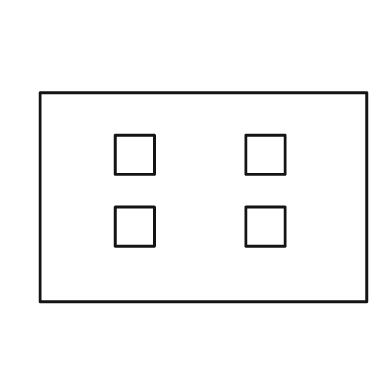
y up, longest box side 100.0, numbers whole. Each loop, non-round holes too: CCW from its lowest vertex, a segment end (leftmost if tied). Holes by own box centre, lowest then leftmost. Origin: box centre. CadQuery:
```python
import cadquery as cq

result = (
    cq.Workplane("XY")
    .moveTo(-50.0, -32.0)
    .lineTo(50.0, -32.0)
    .lineTo(50.0, 32.0)
    .lineTo(-50.0, 32.0)
    .close()
    .moveTo(-27.0, -15.0)
    .lineTo(-15.0, -15.0)
    .lineTo(-15.0, -3.0)
    .lineTo(-27.0, -3.0)
    .close()
    .moveTo(13.0, -15.0)
    .lineTo(25.0, -15.0)
    .lineTo(25.0, -3.0)
    .lineTo(13.0, -3.0)
    .close()
    .moveTo(-27.0, 7.0)
    .lineTo(-15.0, 7.0)
    .lineTo(-15.0, 19.0)
    .lineTo(-27.0, 19.0)
    .close()
    .moveTo(13.0, 7.0)
    .lineTo(25.0, 7.0)
    .lineTo(25.0, 19.0)
    .lineTo(13.0, 19.0)
    .close()
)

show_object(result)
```